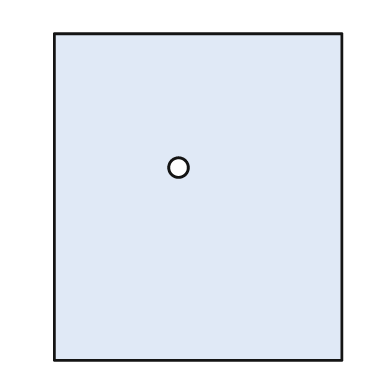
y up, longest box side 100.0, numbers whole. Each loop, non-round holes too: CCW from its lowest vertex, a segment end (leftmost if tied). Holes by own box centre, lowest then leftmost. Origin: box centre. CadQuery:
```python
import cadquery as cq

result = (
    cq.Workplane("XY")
    .moveTo(-44.0, -50.0)
    .lineTo(44.0, -50.0)
    .lineTo(44.0, 50.0)
    .lineTo(-44.0, 50.0)
    .close()
    .moveTo(-6.0, 9.0)
    .circle(3.0)
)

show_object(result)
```